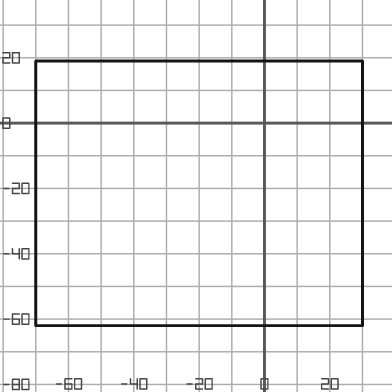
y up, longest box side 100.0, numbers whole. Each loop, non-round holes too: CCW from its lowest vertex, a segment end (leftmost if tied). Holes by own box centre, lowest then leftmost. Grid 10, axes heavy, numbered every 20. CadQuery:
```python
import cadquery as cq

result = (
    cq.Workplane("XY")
    .moveTo(-70.0, -62.0)
    .lineTo(30.0, -62.0)
    .lineTo(30.0, 19.0)
    .lineTo(-70.0, 19.0)
    .close()
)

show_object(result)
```